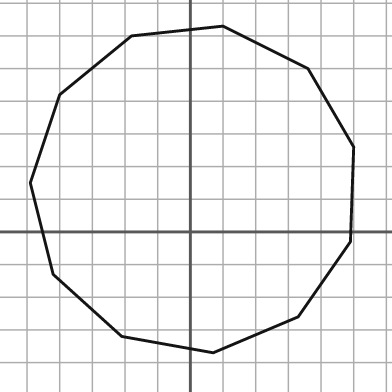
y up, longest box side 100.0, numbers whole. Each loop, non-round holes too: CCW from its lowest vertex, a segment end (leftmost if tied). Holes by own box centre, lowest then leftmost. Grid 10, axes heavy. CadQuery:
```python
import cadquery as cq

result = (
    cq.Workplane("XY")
    .moveTo(7.0, -37.0)
    .lineTo(33.0, -26.0)
    .lineTo(49.0, -3.0)
    .lineTo(50.0, 26.0)
    .lineTo(36.0, 50.0)
    .lineTo(10.0, 63.0)
    .lineTo(-18.0, 60.0)
    .lineTo(-40.0, 42.0)
    .lineTo(-49.0, 15.0)
    .lineTo(-42.0, -13.0)
    .lineTo(-21.0, -32.0)
    .close()
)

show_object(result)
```